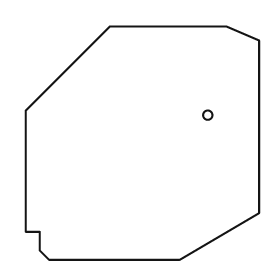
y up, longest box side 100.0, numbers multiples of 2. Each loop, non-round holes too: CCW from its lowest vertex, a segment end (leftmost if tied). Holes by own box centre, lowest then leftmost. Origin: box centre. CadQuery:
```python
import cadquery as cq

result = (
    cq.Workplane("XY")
    .moveTo(-40.0, -50.0)
    .lineTo(16.0, -50.0)
    .lineTo(50.0, -30.0)
    .lineTo(50.0, 44.0)
    .lineTo(36.0, 50.0)
    .lineTo(-14.0, 50.0)
    .lineTo(-50.0, 14.0)
    .lineTo(-50.0, -38.0)
    .lineTo(-44.0, -38.0)
    .lineTo(-44.0, -46.0)
    .close()
    .moveTo(28.0, 12.0)
    .circle(2.0)
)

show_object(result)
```